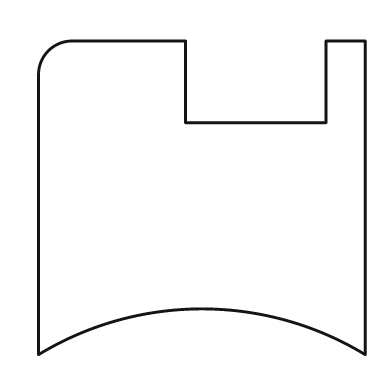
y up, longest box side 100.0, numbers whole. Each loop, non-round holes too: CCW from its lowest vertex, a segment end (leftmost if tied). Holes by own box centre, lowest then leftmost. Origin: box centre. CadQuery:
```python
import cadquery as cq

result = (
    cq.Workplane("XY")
    .moveTo(-50.0, -48.0)
    .threePointArc((0.0, -34.0), (50.0, -48.0))
    .lineTo(50.0, 48.0)
    .lineTo(38.0, 48.0)
    .lineTo(38.0, 23.0)
    .lineTo(-5.0, 23.0)
    .lineTo(-5.0, 48.0)
    .lineTo(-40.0, 48.0)
    .threePointArc((-47.0, 45.0), (-50.0, 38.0))
    .close()
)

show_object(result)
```